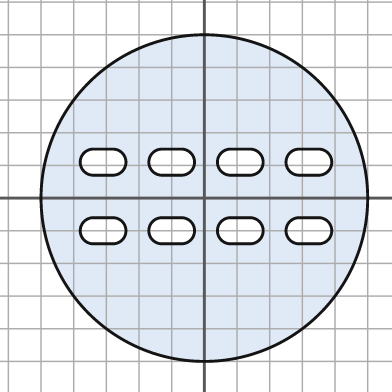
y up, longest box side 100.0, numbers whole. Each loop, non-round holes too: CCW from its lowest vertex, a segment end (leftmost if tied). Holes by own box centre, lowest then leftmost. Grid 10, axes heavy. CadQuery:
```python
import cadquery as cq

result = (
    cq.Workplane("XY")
    .moveTo(0.0, 0.0)
    .circle(50.0)
    .moveTo(-34.0, -14.0)
    .lineTo(-28.0, -14.0)
    .threePointArc((-24.0, -10.0), (-28.0, -6.0))
    .lineTo(-34.0, -6.0)
    .threePointArc((-38.0, -10.0), (-34.0, -14.0))
    .close()
    .moveTo(-13.0, -14.0)
    .lineTo(-7.0, -14.0)
    .threePointArc((-3.0, -10.0), (-7.0, -6.0))
    .lineTo(-13.0, -6.0)
    .threePointArc((-17.0, -10.0), (-13.0, -14.0))
    .close()
    .moveTo(8.0, -14.0)
    .lineTo(14.0, -14.0)
    .threePointArc((18.0, -10.0), (14.0, -6.0))
    .lineTo(8.0, -6.0)
    .threePointArc((4.0, -10.0), (8.0, -14.0))
    .close()
    .moveTo(29.0, -14.0)
    .lineTo(35.0, -14.0)
    .threePointArc((39.0, -10.0), (35.0, -6.0))
    .lineTo(29.0, -6.0)
    .threePointArc((25.0, -10.0), (29.0, -14.0))
    .close()
    .moveTo(-34.0, 7.0)
    .lineTo(-28.0, 7.0)
    .threePointArc((-24.0, 11.0), (-28.0, 15.0))
    .lineTo(-34.0, 15.0)
    .threePointArc((-38.0, 11.0), (-34.0, 7.0))
    .close()
    .moveTo(-13.0, 7.0)
    .lineTo(-7.0, 7.0)
    .threePointArc((-3.0, 11.0), (-7.0, 15.0))
    .lineTo(-13.0, 15.0)
    .threePointArc((-17.0, 11.0), (-13.0, 7.0))
    .close()
    .moveTo(8.0, 7.0)
    .lineTo(14.0, 7.0)
    .threePointArc((18.0, 11.0), (14.0, 15.0))
    .lineTo(8.0, 15.0)
    .threePointArc((4.0, 11.0), (8.0, 7.0))
    .close()
    .moveTo(29.0, 7.0)
    .lineTo(35.0, 7.0)
    .threePointArc((39.0, 11.0), (35.0, 15.0))
    .lineTo(29.0, 15.0)
    .threePointArc((25.0, 11.0), (29.0, 7.0))
    .close()
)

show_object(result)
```